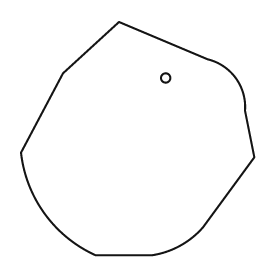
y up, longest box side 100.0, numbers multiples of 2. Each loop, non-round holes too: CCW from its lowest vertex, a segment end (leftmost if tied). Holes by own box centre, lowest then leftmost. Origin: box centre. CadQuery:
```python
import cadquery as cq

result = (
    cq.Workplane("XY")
    .moveTo(-18.0, -50.0)
    .lineTo(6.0, -50.0)
    .threePointArc((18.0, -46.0), (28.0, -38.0))
    .lineTo(50.0, -8.0)
    .lineTo(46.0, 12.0)
    .threePointArc((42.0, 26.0), (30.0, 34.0))
    .lineTo(-8.0, 50.0)
    .lineTo(-32.0, 28.0)
    .lineTo(-50.0, -6.0)
    .threePointArc((-40.0, -32.0), (-18.0, -50.0))
    .close()
    .moveTo(12.0, 26.0)
    .circle(2.0)
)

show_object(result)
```